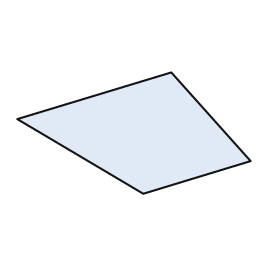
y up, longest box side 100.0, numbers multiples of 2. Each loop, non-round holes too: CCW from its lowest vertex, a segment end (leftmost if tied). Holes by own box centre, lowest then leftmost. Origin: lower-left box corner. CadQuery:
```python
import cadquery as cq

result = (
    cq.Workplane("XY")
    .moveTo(54.0, 0.0)
    .lineTo(100.0, 14.0)
    .lineTo(66.0, 52.0)
    .lineTo(0.0, 32.0)
    .close()
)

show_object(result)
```